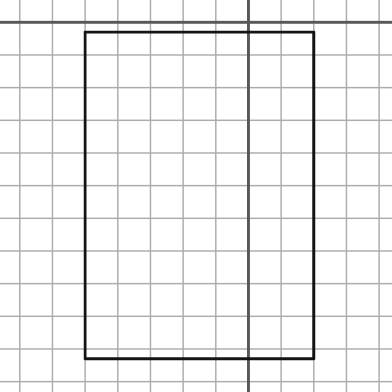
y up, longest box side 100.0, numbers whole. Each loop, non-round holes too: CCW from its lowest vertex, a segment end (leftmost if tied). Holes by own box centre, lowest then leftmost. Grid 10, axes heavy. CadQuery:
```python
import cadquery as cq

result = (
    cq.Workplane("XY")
    .moveTo(-50.0, -103.0)
    .lineTo(20.0, -103.0)
    .lineTo(20.0, -3.0)
    .lineTo(-50.0, -3.0)
    .close()
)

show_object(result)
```